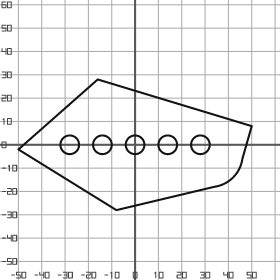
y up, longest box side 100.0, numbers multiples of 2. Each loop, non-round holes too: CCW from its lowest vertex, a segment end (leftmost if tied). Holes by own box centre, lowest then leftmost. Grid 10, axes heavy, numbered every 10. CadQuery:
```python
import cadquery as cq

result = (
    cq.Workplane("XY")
    .moveTo(-8.0, -28.0)
    .lineTo(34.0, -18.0)
    .threePointArc((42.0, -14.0), (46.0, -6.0))
    .lineTo(50.0, 8.0)
    .lineTo(-16.0, 28.0)
    .lineTo(-50.0, -2.0)
    .close()
    .moveTo(-28.0, 0.0)
    .circle(4.0)
    .moveTo(-14.0, 0.0)
    .circle(4.0)
    .moveTo(0.0, 0.0)
    .circle(4.0)
    .moveTo(14.0, 0.0)
    .circle(4.0)
    .moveTo(28.0, 0.0)
    .circle(4.0)
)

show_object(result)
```